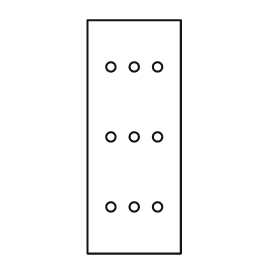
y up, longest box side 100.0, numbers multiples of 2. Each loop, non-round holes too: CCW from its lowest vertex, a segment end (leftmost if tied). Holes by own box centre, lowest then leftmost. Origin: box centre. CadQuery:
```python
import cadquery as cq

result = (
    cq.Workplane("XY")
    .moveTo(-20.0, -50.0)
    .lineTo(20.0, -50.0)
    .lineTo(20.0, 50.0)
    .lineTo(-20.0, 50.0)
    .close()
    .moveTo(-10.0, -30.0)
    .circle(2.0)
    .moveTo(0.0, -30.0)
    .circle(2.0)
    .moveTo(10.0, -30.0)
    .circle(2.0)
    .moveTo(-10.0, 0.0)
    .circle(2.0)
    .moveTo(0.0, 0.0)
    .circle(2.0)
    .moveTo(10.0, 0.0)
    .circle(2.0)
    .moveTo(-10.0, 30.0)
    .circle(2.0)
    .moveTo(0.0, 30.0)
    .circle(2.0)
    .moveTo(10.0, 30.0)
    .circle(2.0)
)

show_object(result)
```